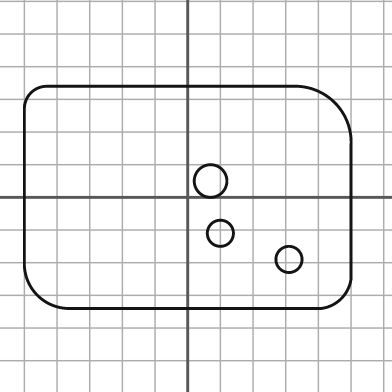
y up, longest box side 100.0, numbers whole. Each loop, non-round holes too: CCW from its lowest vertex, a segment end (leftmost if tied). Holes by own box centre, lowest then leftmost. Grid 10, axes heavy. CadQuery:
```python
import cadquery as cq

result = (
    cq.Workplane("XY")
    .moveTo(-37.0, -34.0)
    .lineTo(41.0, -34.0)
    .threePointArc((47.0, -31.0), (50.0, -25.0))
    .lineTo(50.0, 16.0)
    .threePointArc((45.0, 29.0), (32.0, 34.0))
    .lineTo(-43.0, 34.0)
    .threePointArc((-48.0, 32.0), (-50.0, 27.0))
    .lineTo(-50.0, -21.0)
    .threePointArc((-46.0, -30.0), (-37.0, -34.0))
    .close()
    .moveTo(31.0, -19.0)
    .circle(4.0)
    .moveTo(10.0, -11.0)
    .circle(4.0)
    .moveTo(7.0, 5.0)
    .circle(5.0)
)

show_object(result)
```